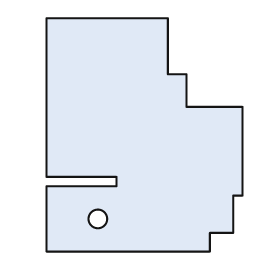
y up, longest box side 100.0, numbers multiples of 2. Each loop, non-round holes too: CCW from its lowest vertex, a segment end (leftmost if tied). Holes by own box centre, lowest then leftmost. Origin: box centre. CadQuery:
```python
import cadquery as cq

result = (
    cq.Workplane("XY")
    .moveTo(-42.0, -50.0)
    .lineTo(28.0, -50.0)
    .lineTo(28.0, -42.0)
    .lineTo(38.0, -42.0)
    .lineTo(38.0, -26.0)
    .lineTo(42.0, -26.0)
    .lineTo(42.0, 12.0)
    .lineTo(18.0, 12.0)
    .lineTo(18.0, 26.0)
    .lineTo(10.0, 26.0)
    .lineTo(10.0, 50.0)
    .lineTo(-42.0, 50.0)
    .lineTo(-42.0, -18.0)
    .lineTo(-12.0, -18.0)
    .lineTo(-12.0, -22.0)
    .lineTo(-42.0, -22.0)
    .close()
    .moveTo(-20.0, -36.0)
    .circle(4.0)
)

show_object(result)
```